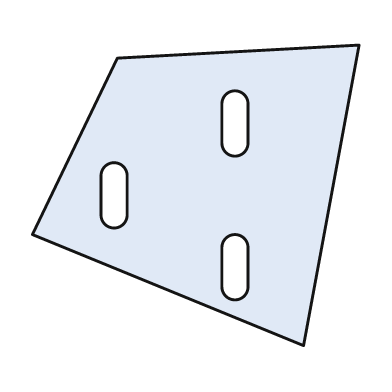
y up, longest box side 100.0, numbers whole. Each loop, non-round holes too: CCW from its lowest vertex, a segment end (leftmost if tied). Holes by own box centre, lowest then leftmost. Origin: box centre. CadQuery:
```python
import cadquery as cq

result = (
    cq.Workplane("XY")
    .moveTo(33.0, -46.0)
    .lineTo(50.0, 46.0)
    .lineTo(-24.0, 42.0)
    .lineTo(-50.0, -12.0)
    .close()
    .moveTo(8.0, -28.0)
    .threePointArc((12.0, -32.0), (16.0, -28.0))
    .lineTo(16.0, -16.0)
    .threePointArc((12.0, -12.0), (8.0, -16.0))
    .close()
    .moveTo(-29.0, -6.0)
    .threePointArc((-25.0, -10.0), (-21.0, -6.0))
    .lineTo(-21.0, 6.0)
    .threePointArc((-25.0, 10.0), (-29.0, 6.0))
    .close()
    .moveTo(8.0, 16.0)
    .threePointArc((12.0, 12.0), (16.0, 16.0))
    .lineTo(16.0, 28.0)
    .threePointArc((12.0, 32.0), (8.0, 28.0))
    .close()
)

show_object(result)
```